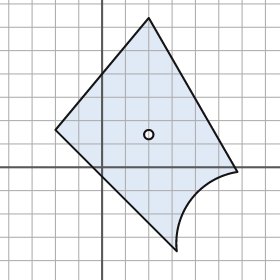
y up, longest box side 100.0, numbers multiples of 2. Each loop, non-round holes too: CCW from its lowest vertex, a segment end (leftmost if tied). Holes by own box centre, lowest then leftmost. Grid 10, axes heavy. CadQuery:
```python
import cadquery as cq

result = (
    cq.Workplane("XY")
    .moveTo(32.0, -36.0)
    .threePointArc((38.0, -14.0), (58.0, -2.0))
    .lineTo(20.0, 64.0)
    .lineTo(-20.0, 16.0)
    .close()
    .moveTo(20.0, 14.0)
    .circle(2.0)
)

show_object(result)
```